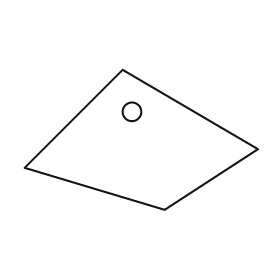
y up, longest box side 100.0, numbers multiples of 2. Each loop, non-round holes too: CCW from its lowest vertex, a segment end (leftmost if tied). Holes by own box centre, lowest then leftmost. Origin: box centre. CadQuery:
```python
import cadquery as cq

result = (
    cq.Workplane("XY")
    .moveTo(10.0, -30.0)
    .lineTo(50.0, -4.0)
    .lineTo(-8.0, 30.0)
    .lineTo(-50.0, -12.0)
    .close()
    .moveTo(-4.0, 12.0)
    .circle(4.0)
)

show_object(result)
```